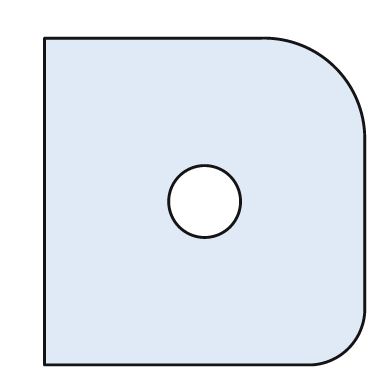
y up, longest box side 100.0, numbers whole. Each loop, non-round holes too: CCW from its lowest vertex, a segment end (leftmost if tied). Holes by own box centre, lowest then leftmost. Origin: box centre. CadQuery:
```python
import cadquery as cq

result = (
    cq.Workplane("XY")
    .moveTo(-49.0, -50.0)
    .lineTo(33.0, -50.0)
    .threePointArc((44.0, -45.0), (49.0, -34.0))
    .lineTo(49.0, 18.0)
    .threePointArc((40.0, 41.0), (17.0, 50.0))
    .lineTo(-49.0, 50.0)
    .close()
    .moveTo(0.0, 0.0)
    .circle(11.0)
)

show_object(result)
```